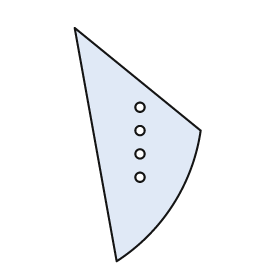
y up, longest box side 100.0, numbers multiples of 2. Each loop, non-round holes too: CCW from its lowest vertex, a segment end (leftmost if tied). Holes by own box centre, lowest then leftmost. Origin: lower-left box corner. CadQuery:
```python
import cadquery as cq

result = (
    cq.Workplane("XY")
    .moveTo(18.0, 0.0)
    .threePointArc((42.0, 24.0), (54.0, 56.0))
    .lineTo(0.0, 100.0)
    .close()
    .moveTo(28.0, 36.0)
    .circle(2.0)
    .moveTo(28.0, 46.0)
    .circle(2.0)
    .moveTo(28.0, 56.0)
    .circle(2.0)
    .moveTo(28.0, 66.0)
    .circle(2.0)
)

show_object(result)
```